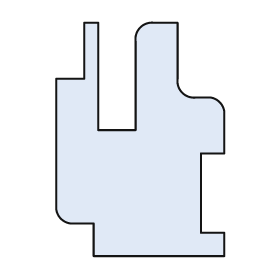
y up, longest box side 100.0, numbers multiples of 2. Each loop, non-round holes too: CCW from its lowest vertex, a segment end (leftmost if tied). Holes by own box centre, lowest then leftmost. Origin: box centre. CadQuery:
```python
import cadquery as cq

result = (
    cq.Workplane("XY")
    .moveTo(-20.0, -50.0)
    .lineTo(36.0, -50.0)
    .lineTo(36.0, -40.0)
    .lineTo(26.0, -40.0)
    .lineTo(26.0, -6.0)
    .lineTo(36.0, -6.0)
    .lineTo(36.0, 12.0)
    .threePointArc((34.0, 16.0), (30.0, 18.0))
    .lineTo(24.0, 18.0)
    .threePointArc((18.0, 20.0), (16.0, 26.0))
    .lineTo(16.0, 50.0)
    .lineTo(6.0, 50.0)
    .threePointArc((0.0, 48.0), (-2.0, 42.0))
    .lineTo(-2.0, 4.0)
    .lineTo(-18.0, 4.0)
    .lineTo(-18.0, 50.0)
    .lineTo(-24.0, 50.0)
    .lineTo(-24.0, 26.0)
    .lineTo(-36.0, 26.0)
    .lineTo(-36.0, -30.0)
    .threePointArc((-34.0, -34.0), (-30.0, -36.0))
    .lineTo(-20.0, -36.0)
    .close()
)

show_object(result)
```